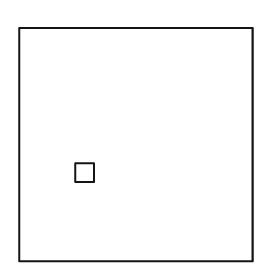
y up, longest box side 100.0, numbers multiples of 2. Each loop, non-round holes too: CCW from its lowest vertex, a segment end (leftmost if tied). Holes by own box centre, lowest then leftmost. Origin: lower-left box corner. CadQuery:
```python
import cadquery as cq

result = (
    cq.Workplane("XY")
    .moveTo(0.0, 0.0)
    .lineTo(100.0, 0.0)
    .lineTo(100.0, 100.0)
    .lineTo(0.0, 100.0)
    .close()
    .moveTo(24.0, 34.0)
    .lineTo(32.0, 34.0)
    .lineTo(32.0, 42.0)
    .lineTo(24.0, 42.0)
    .close()
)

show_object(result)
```